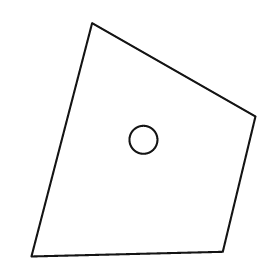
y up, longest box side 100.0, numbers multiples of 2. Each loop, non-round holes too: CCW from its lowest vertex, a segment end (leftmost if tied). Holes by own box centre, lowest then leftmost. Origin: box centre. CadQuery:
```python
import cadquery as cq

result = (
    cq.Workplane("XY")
    .moveTo(-48.0, -50.0)
    .lineTo(34.0, -48.0)
    .lineTo(48.0, 10.0)
    .lineTo(-22.0, 50.0)
    .close()
    .moveTo(0.0, 0.0)
    .circle(6.0)
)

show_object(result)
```